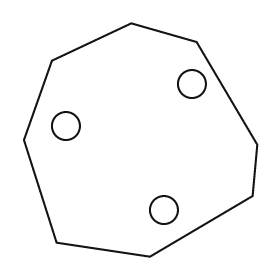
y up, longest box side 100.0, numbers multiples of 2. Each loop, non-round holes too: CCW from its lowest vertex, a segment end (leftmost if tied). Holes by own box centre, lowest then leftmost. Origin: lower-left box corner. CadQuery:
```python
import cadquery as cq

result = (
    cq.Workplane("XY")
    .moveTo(54.0, 0.0)
    .lineTo(98.0, 26.0)
    .lineTo(100.0, 48.0)
    .lineTo(74.0, 92.0)
    .lineTo(46.0, 100.0)
    .lineTo(12.0, 84.0)
    .lineTo(0.0, 50.0)
    .lineTo(14.0, 6.0)
    .close()
    .moveTo(60.0, 20.0)
    .circle(6.0)
    .moveTo(18.0, 56.0)
    .circle(6.0)
    .moveTo(72.0, 74.0)
    .circle(6.0)
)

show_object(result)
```